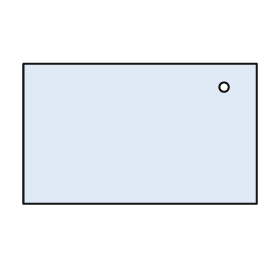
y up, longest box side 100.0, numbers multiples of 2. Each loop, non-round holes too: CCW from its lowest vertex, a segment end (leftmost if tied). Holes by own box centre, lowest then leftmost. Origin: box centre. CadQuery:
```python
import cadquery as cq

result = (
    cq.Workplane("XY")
    .moveTo(-50.0, -30.0)
    .lineTo(50.0, -30.0)
    .lineTo(50.0, 30.0)
    .lineTo(-50.0, 30.0)
    .close()
    .moveTo(36.0, 20.0)
    .circle(2.0)
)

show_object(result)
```